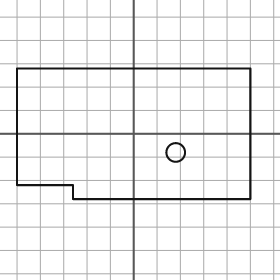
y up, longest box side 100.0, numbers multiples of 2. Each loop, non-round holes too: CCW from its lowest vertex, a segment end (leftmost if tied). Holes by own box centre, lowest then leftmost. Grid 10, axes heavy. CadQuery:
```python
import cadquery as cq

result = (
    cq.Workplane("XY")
    .moveTo(-26.0, -28.0)
    .lineTo(50.0, -28.0)
    .lineTo(50.0, 28.0)
    .lineTo(-50.0, 28.0)
    .lineTo(-50.0, -22.0)
    .lineTo(-26.0, -22.0)
    .close()
    .moveTo(18.0, -8.0)
    .circle(4.0)
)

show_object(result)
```